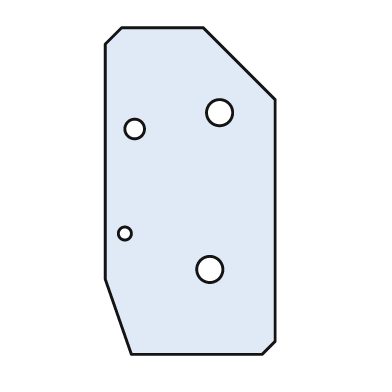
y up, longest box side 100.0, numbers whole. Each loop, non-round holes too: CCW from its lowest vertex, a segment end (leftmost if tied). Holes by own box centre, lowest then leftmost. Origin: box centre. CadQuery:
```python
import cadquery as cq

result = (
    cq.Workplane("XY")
    .moveTo(-18.0, -50.0)
    .lineTo(22.0, -50.0)
    .lineTo(26.0, -46.0)
    .lineTo(26.0, 28.0)
    .lineTo(4.0, 50.0)
    .lineTo(-21.0, 50.0)
    .lineTo(-26.0, 45.0)
    .lineTo(-26.0, -27.0)
    .close()
    .moveTo(6.0, -24.0)
    .circle(4.0)
    .moveTo(-20.0, -13.0)
    .circle(2.0)
    .moveTo(-17.0, 19.0)
    .circle(3.0)
    .moveTo(9.0, 24.0)
    .circle(4.0)
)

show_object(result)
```